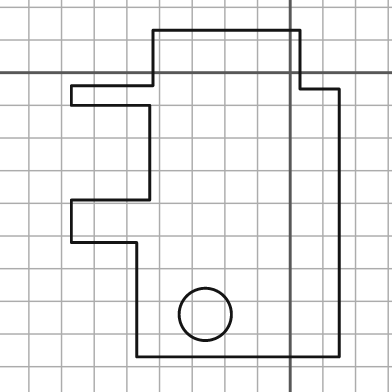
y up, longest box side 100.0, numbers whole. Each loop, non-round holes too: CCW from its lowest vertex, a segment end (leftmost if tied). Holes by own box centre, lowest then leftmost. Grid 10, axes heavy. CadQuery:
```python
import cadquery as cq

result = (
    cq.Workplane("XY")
    .moveTo(-47.0, -87.0)
    .lineTo(15.0, -87.0)
    .lineTo(15.0, -5.0)
    .lineTo(3.0, -5.0)
    .lineTo(3.0, 13.0)
    .lineTo(-42.0, 13.0)
    .lineTo(-42.0, -4.0)
    .lineTo(-67.0, -4.0)
    .lineTo(-67.0, -10.0)
    .lineTo(-43.0, -10.0)
    .lineTo(-43.0, -39.0)
    .lineTo(-67.0, -39.0)
    .lineTo(-67.0, -52.0)
    .lineTo(-47.0, -52.0)
    .close()
    .moveTo(-26.0, -74.0)
    .circle(8.0)
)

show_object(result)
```